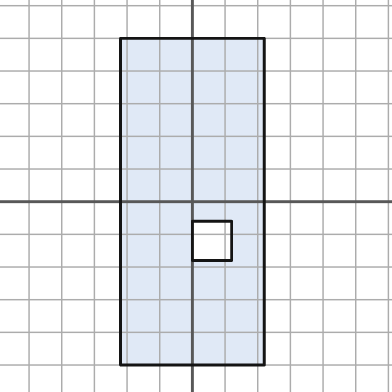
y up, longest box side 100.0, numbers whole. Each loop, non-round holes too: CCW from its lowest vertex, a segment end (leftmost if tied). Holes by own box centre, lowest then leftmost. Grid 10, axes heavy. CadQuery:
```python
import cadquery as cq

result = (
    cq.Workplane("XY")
    .moveTo(-22.0, -50.0)
    .lineTo(22.0, -50.0)
    .lineTo(22.0, 50.0)
    .lineTo(-22.0, 50.0)
    .close()
    .moveTo(0.0, -18.0)
    .lineTo(12.0, -18.0)
    .lineTo(12.0, -6.0)
    .lineTo(0.0, -6.0)
    .close()
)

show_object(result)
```